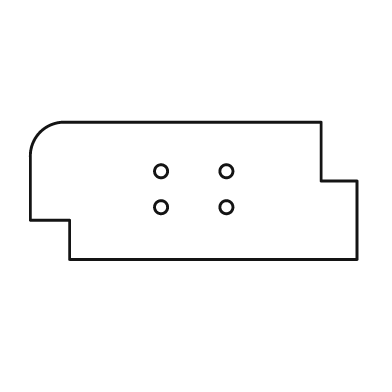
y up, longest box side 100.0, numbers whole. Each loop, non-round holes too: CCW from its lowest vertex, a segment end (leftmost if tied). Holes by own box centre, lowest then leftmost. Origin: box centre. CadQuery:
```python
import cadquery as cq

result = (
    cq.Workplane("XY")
    .moveTo(-38.0, -21.0)
    .lineTo(50.0, -21.0)
    .lineTo(50.0, 3.0)
    .lineTo(39.0, 3.0)
    .lineTo(39.0, 21.0)
    .lineTo(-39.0, 21.0)
    .threePointArc((-47.0, 18.0), (-50.0, 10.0))
    .lineTo(-50.0, -9.0)
    .lineTo(-38.0, -9.0)
    .close()
    .moveTo(-10.0, -5.0)
    .circle(2.0)
    .moveTo(10.0, -5.0)
    .circle(2.0)
    .moveTo(-10.0, 6.0)
    .circle(2.0)
    .moveTo(10.0, 6.0)
    .circle(2.0)
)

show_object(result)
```